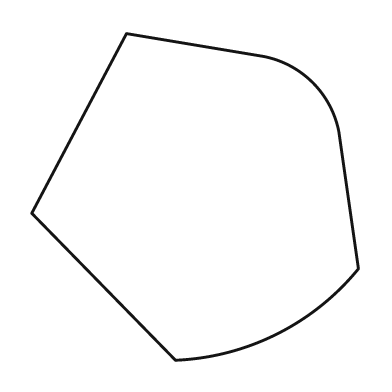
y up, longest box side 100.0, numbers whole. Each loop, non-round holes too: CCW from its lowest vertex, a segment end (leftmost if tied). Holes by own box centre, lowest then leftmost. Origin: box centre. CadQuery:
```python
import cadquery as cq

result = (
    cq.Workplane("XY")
    .moveTo(-6.0, -50.0)
    .threePointArc((25.0, -42.0), (50.0, -22.0))
    .lineTo(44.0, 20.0)
    .threePointArc((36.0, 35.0), (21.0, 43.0))
    .lineTo(-21.0, 50.0)
    .lineTo(-50.0, -5.0)
    .close()
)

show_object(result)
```